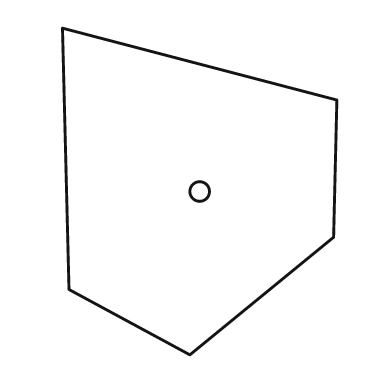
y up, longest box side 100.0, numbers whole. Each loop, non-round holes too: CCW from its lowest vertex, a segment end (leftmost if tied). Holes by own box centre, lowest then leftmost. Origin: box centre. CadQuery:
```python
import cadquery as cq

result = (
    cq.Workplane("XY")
    .moveTo(-3.0, -50.0)
    .lineTo(41.0, -14.0)
    .lineTo(42.0, 28.0)
    .lineTo(-42.0, 50.0)
    .lineTo(-40.0, -30.0)
    .close()
    .moveTo(0.0, 0.0)
    .circle(3.0)
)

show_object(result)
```